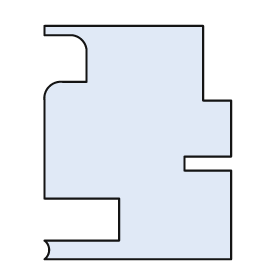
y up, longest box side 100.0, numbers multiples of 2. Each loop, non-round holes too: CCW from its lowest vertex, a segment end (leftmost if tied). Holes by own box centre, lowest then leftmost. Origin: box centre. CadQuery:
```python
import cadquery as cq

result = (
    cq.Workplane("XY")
    .moveTo(-40.0, -50.0)
    .lineTo(40.0, -50.0)
    .lineTo(40.0, -12.0)
    .lineTo(20.0, -12.0)
    .lineTo(20.0, -6.0)
    .lineTo(40.0, -6.0)
    .lineTo(40.0, 18.0)
    .lineTo(28.0, 18.0)
    .lineTo(28.0, 50.0)
    .lineTo(-40.0, 50.0)
    .lineTo(-40.0, 46.0)
    .lineTo(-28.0, 46.0)
    .threePointArc((-24.0, 44.0), (-22.0, 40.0))
    .lineTo(-22.0, 26.0)
    .lineTo(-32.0, 26.0)
    .threePointArc((-38.0, 24.0), (-40.0, 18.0))
    .lineTo(-40.0, -24.0)
    .lineTo(-8.0, -24.0)
    .lineTo(-8.0, -42.0)
    .lineTo(-40.0, -42.0)
    .threePointArc((-38.0, -46.0), (-40.0, -50.0))
    .close()
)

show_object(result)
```